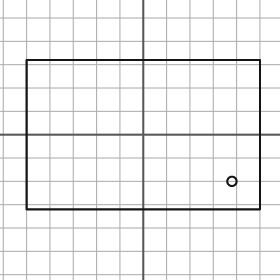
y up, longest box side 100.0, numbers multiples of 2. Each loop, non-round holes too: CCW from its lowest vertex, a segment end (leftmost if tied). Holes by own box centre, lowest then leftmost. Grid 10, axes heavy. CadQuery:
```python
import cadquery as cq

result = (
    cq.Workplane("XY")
    .moveTo(-50.0, -32.0)
    .lineTo(50.0, -32.0)
    .lineTo(50.0, 32.0)
    .lineTo(-50.0, 32.0)
    .close()
    .moveTo(38.0, -20.0)
    .circle(2.0)
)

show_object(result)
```